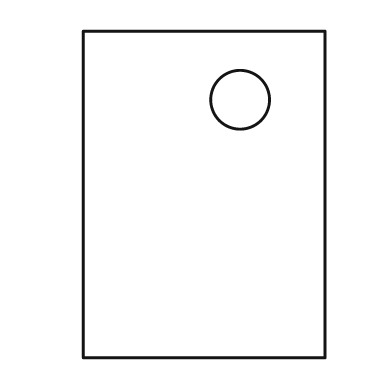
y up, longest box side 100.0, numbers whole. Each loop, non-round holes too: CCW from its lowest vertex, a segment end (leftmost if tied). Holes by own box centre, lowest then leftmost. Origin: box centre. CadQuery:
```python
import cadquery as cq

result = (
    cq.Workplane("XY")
    .moveTo(-37.0, -50.0)
    .lineTo(37.0, -50.0)
    .lineTo(37.0, 50.0)
    .lineTo(-37.0, 50.0)
    .close()
    .moveTo(11.0, 29.0)
    .circle(9.0)
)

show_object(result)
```